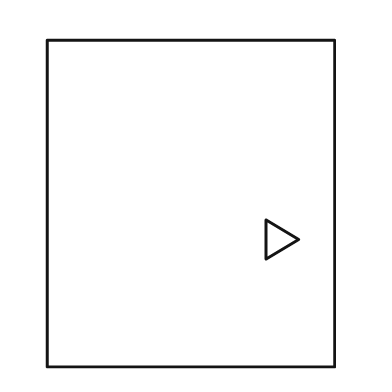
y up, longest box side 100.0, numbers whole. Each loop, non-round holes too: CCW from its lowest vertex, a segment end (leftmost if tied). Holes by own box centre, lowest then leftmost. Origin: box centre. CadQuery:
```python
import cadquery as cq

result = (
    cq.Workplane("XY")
    .moveTo(-44.0, -50.0)
    .lineTo(44.0, -50.0)
    .lineTo(44.0, 50.0)
    .lineTo(-44.0, 50.0)
    .close()
    .moveTo(23.0, -17.0)
    .lineTo(33.0, -11.0)
    .lineTo(23.0, -5.0)
    .close()
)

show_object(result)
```